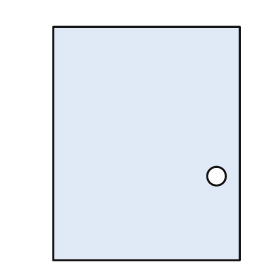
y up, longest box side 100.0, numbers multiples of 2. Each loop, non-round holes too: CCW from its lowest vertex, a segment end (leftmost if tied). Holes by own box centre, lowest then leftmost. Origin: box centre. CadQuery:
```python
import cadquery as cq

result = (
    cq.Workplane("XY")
    .moveTo(-40.0, -50.0)
    .lineTo(40.0, -50.0)
    .lineTo(40.0, 50.0)
    .lineTo(-40.0, 50.0)
    .close()
    .moveTo(30.0, -14.0)
    .circle(4.0)
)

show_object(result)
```